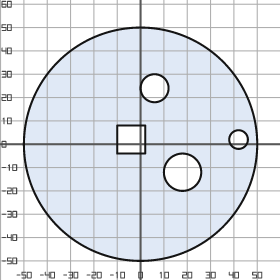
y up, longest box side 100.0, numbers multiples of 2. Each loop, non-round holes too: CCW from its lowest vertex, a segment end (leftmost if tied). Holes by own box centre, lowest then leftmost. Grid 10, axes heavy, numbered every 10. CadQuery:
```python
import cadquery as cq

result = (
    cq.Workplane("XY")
    .moveTo(0.0, 0.0)
    .circle(50.0)
    .moveTo(18.0, -12.0)
    .circle(8.0)
    .moveTo(-10.0, -4.0)
    .lineTo(2.0, -4.0)
    .lineTo(2.0, 8.0)
    .lineTo(-10.0, 8.0)
    .close()
    .moveTo(42.0, 2.0)
    .circle(4.0)
    .moveTo(6.0, 24.0)
    .circle(6.0)
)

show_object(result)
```